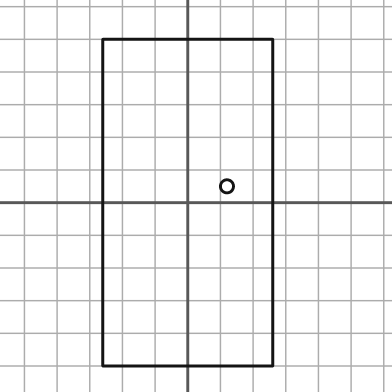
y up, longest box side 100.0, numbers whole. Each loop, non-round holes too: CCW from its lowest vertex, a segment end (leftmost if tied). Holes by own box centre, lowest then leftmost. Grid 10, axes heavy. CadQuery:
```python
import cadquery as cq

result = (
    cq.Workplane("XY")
    .moveTo(-26.0, -50.0)
    .lineTo(26.0, -50.0)
    .lineTo(26.0, 50.0)
    .lineTo(-26.0, 50.0)
    .close()
    .moveTo(12.0, 5.0)
    .circle(2.0)
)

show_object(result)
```